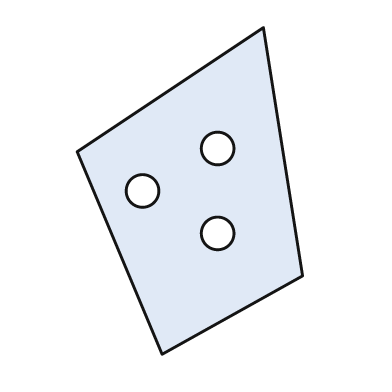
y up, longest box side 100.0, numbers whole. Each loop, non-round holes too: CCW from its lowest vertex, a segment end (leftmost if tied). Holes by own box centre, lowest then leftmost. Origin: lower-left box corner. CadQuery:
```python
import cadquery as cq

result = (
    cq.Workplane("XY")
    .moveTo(26.0, 0.0)
    .lineTo(69.0, 24.0)
    .lineTo(57.0, 100.0)
    .lineTo(0.0, 62.0)
    .close()
    .moveTo(43.0, 37.0)
    .circle(5.0)
    .moveTo(20.0, 50.0)
    .circle(5.0)
    .moveTo(43.0, 63.0)
    .circle(5.0)
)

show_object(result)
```